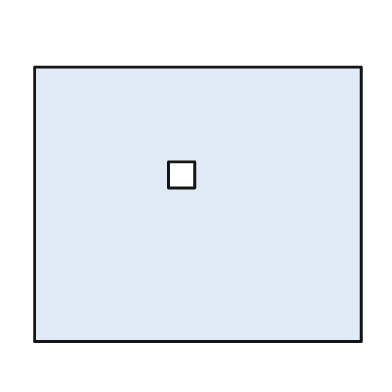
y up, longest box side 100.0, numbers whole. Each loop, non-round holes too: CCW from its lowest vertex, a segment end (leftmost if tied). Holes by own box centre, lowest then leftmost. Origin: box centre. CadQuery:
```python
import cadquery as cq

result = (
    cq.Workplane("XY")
    .moveTo(-50.0, -42.0)
    .lineTo(50.0, -42.0)
    .lineTo(50.0, 42.0)
    .lineTo(-50.0, 42.0)
    .close()
    .moveTo(-9.0, 5.0)
    .lineTo(-1.0, 5.0)
    .lineTo(-1.0, 13.0)
    .lineTo(-9.0, 13.0)
    .close()
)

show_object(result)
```